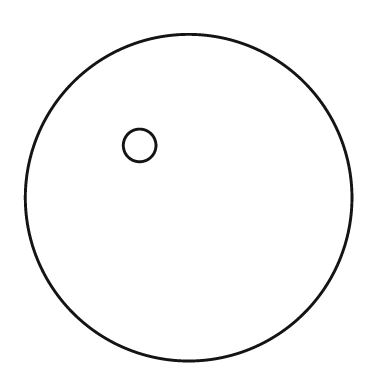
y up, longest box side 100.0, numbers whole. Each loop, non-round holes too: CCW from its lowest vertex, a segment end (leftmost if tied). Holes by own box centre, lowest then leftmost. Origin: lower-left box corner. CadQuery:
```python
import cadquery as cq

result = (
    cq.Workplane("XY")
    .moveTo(50.0, 50.0)
    .circle(50.0)
    .moveTo(35.0, 66.0)
    .circle(5.0)
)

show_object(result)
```